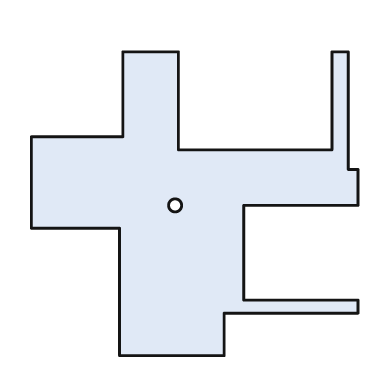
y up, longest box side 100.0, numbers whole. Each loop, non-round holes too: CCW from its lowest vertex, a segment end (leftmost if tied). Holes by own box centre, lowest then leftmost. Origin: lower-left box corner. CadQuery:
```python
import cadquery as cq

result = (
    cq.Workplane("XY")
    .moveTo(27.0, 0.0)
    .lineTo(59.0, 0.0)
    .lineTo(59.0, 13.0)
    .lineTo(100.0, 13.0)
    .lineTo(100.0, 17.0)
    .lineTo(65.0, 17.0)
    .lineTo(65.0, 46.0)
    .lineTo(100.0, 46.0)
    .lineTo(100.0, 57.0)
    .lineTo(97.0, 57.0)
    .lineTo(97.0, 93.0)
    .lineTo(92.0, 93.0)
    .lineTo(92.0, 63.0)
    .lineTo(45.0, 63.0)
    .lineTo(45.0, 93.0)
    .lineTo(28.0, 93.0)
    .lineTo(28.0, 67.0)
    .lineTo(0.0, 67.0)
    .lineTo(0.0, 39.0)
    .lineTo(27.0, 39.0)
    .close()
    .moveTo(44.0, 46.0)
    .circle(2.0)
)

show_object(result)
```